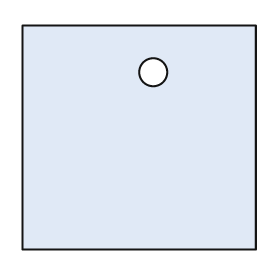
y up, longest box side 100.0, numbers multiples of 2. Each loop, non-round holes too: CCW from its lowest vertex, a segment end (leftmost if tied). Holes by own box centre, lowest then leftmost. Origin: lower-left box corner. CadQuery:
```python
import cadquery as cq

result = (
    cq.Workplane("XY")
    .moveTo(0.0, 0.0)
    .lineTo(100.0, 0.0)
    .lineTo(100.0, 96.0)
    .lineTo(0.0, 96.0)
    .close()
    .moveTo(56.0, 76.0)
    .circle(6.0)
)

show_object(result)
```